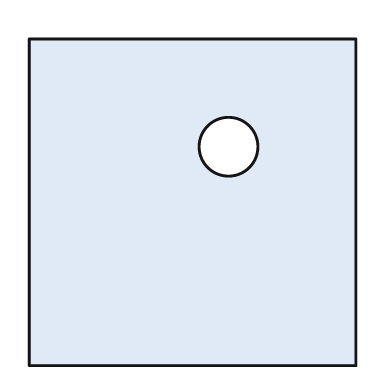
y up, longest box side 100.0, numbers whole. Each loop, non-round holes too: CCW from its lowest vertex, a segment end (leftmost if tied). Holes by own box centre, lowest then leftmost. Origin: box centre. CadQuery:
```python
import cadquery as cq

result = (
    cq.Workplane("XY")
    .moveTo(-50.0, -50.0)
    .lineTo(50.0, -50.0)
    .lineTo(50.0, 50.0)
    .lineTo(-50.0, 50.0)
    .close()
    .moveTo(11.0, 17.0)
    .circle(9.0)
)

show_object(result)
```